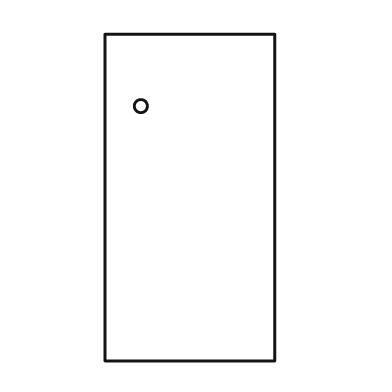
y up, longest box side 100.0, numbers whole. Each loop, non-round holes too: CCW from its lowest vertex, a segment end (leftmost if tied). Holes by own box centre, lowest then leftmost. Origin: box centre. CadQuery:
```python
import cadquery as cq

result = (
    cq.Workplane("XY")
    .moveTo(-26.0, -50.0)
    .lineTo(26.0, -50.0)
    .lineTo(26.0, 50.0)
    .lineTo(-26.0, 50.0)
    .close()
    .moveTo(-15.0, 28.0)
    .circle(2.0)
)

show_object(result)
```